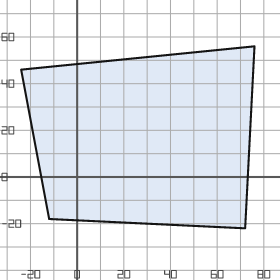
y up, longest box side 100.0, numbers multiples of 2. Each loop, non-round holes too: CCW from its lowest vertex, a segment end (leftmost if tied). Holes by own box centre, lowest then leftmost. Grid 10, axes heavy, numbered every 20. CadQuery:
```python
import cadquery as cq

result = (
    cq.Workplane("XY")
    .moveTo(72.0, -22.0)
    .lineTo(76.0, 56.0)
    .lineTo(-24.0, 46.0)
    .lineTo(-12.0, -18.0)
    .close()
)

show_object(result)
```